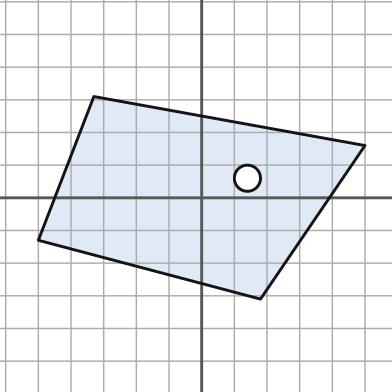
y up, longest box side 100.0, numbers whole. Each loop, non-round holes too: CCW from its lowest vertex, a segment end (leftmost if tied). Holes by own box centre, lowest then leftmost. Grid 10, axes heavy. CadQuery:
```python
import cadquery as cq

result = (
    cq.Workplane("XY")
    .moveTo(18.0, -31.0)
    .lineTo(50.0, 16.0)
    .lineTo(-33.0, 31.0)
    .lineTo(-50.0, -13.0)
    .close()
    .moveTo(14.0, 6.0)
    .circle(4.0)
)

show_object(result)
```